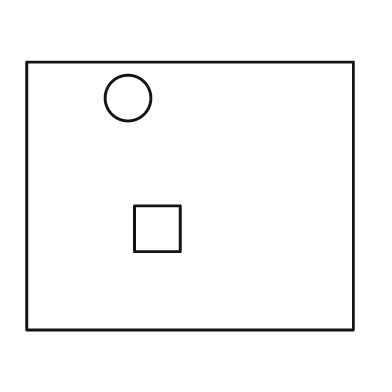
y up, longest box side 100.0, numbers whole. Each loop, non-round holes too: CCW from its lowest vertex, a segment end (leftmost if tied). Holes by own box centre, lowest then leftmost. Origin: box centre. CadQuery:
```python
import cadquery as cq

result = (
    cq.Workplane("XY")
    .moveTo(-50.0, -41.0)
    .lineTo(50.0, -41.0)
    .lineTo(50.0, 41.0)
    .lineTo(-50.0, 41.0)
    .close()
    .moveTo(-17.0, -17.0)
    .lineTo(-3.0, -17.0)
    .lineTo(-3.0, -3.0)
    .lineTo(-17.0, -3.0)
    .close()
    .moveTo(-19.0, 30.0)
    .circle(7.0)
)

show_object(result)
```